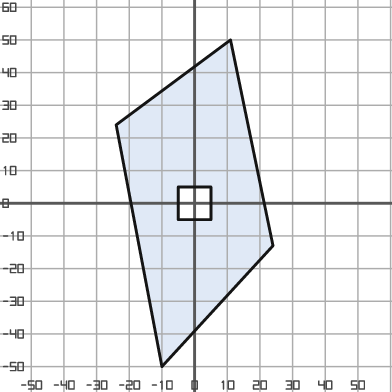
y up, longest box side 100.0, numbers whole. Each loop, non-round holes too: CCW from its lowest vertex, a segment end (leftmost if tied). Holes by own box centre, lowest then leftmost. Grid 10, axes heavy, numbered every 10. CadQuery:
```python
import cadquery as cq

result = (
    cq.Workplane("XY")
    .moveTo(-10.0, -50.0)
    .lineTo(24.0, -13.0)
    .lineTo(11.0, 50.0)
    .lineTo(-24.0, 24.0)
    .close()
    .moveTo(-5.0, -5.0)
    .lineTo(5.0, -5.0)
    .lineTo(5.0, 5.0)
    .lineTo(-5.0, 5.0)
    .close()
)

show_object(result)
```